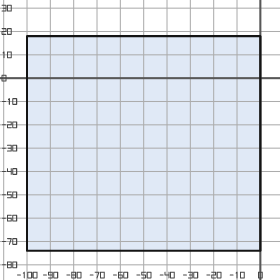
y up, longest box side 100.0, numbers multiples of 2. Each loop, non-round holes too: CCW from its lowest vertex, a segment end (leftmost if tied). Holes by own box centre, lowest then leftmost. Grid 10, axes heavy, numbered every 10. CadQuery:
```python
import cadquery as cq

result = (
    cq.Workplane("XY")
    .moveTo(-100.0, -74.0)
    .lineTo(0.0, -74.0)
    .lineTo(0.0, 18.0)
    .lineTo(-100.0, 18.0)
    .close()
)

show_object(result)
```